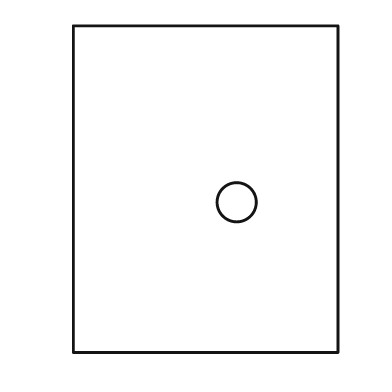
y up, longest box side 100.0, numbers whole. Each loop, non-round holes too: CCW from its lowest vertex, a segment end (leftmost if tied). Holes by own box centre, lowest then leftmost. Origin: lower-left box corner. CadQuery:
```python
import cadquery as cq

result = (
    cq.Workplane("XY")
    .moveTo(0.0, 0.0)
    .lineTo(81.0, 0.0)
    .lineTo(81.0, 100.0)
    .lineTo(0.0, 100.0)
    .close()
    .moveTo(50.0, 46.0)
    .circle(6.0)
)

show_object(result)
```